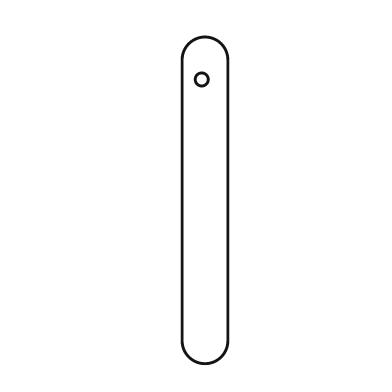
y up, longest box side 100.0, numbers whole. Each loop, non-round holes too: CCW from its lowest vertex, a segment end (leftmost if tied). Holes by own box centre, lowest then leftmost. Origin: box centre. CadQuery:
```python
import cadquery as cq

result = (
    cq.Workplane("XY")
    .moveTo(-7.0, -43.0)
    .threePointArc((0.0, -50.0), (7.0, -43.0))
    .lineTo(7.0, 43.0)
    .threePointArc((0.0, 50.0), (-7.0, 43.0))
    .close()
    .moveTo(-1.0, 37.0)
    .circle(2.0)
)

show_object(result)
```